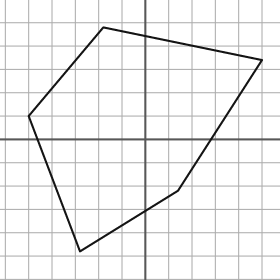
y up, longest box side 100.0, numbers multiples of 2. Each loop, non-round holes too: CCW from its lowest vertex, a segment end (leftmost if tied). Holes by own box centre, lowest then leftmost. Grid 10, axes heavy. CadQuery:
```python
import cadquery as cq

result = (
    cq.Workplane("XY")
    .moveTo(-28.0, -48.0)
    .lineTo(14.0, -22.0)
    .lineTo(50.0, 34.0)
    .lineTo(-18.0, 48.0)
    .lineTo(-50.0, 10.0)
    .close()
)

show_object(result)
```